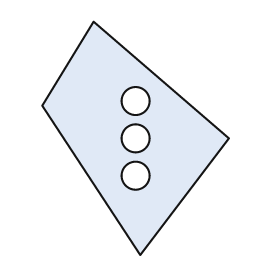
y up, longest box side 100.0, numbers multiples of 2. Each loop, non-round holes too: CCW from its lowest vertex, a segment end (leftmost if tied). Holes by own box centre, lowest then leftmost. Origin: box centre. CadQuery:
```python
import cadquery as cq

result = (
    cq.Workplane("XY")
    .moveTo(2.0, -50.0)
    .lineTo(40.0, 0.0)
    .lineTo(-18.0, 50.0)
    .lineTo(-40.0, 14.0)
    .close()
    .moveTo(0.0, -16.0)
    .circle(6.0)
    .moveTo(0.0, 0.0)
    .circle(6.0)
    .moveTo(0.0, 16.0)
    .circle(6.0)
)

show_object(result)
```